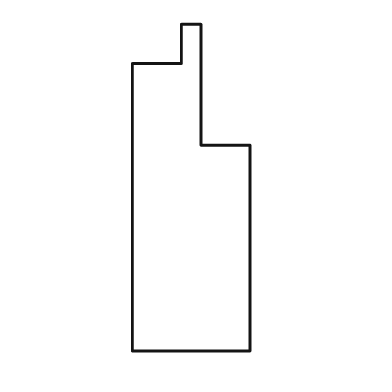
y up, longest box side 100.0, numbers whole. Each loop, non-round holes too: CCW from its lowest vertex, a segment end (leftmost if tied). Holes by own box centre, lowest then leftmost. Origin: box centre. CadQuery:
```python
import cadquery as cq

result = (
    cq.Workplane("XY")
    .moveTo(-18.0, -50.0)
    .lineTo(18.0, -50.0)
    .lineTo(18.0, 13.0)
    .lineTo(3.0, 13.0)
    .lineTo(3.0, 50.0)
    .lineTo(-3.0, 50.0)
    .lineTo(-3.0, 38.0)
    .lineTo(-18.0, 38.0)
    .close()
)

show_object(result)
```